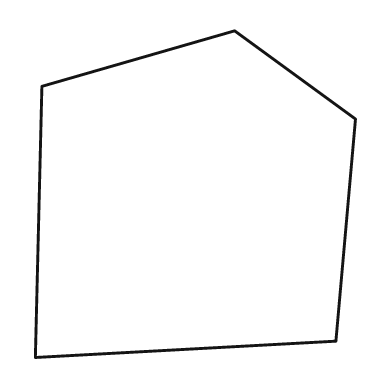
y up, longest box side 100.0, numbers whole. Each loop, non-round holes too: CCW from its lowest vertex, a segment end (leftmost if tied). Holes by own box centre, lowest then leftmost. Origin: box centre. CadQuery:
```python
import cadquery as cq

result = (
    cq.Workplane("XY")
    .moveTo(-49.0, -50.0)
    .lineTo(43.0, -45.0)
    .lineTo(49.0, 23.0)
    .lineTo(12.0, 50.0)
    .lineTo(-47.0, 33.0)
    .close()
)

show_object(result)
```